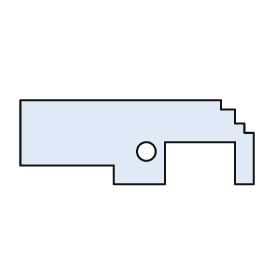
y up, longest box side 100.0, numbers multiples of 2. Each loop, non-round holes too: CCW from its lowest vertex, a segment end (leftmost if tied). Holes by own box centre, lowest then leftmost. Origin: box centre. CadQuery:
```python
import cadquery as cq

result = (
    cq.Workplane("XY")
    .moveTo(-10.0, -18.0)
    .lineTo(12.0, -18.0)
    .lineTo(12.0, 0.0)
    .lineTo(42.0, 0.0)
    .lineTo(42.0, -18.0)
    .lineTo(50.0, -18.0)
    .lineTo(50.0, 4.0)
    .lineTo(46.0, 4.0)
    .lineTo(46.0, 8.0)
    .lineTo(42.0, 8.0)
    .lineTo(42.0, 14.0)
    .lineTo(36.0, 14.0)
    .lineTo(36.0, 18.0)
    .lineTo(-50.0, 18.0)
    .lineTo(-50.0, -10.0)
    .lineTo(-10.0, -10.0)
    .close()
    .moveTo(4.0, -4.0)
    .circle(4.0)
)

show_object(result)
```